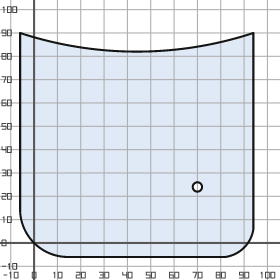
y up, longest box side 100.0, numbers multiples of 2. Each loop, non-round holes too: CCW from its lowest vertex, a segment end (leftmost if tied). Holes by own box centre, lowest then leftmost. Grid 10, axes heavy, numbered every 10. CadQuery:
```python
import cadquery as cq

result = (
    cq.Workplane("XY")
    .moveTo(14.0, -6.0)
    .lineTo(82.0, -6.0)
    .threePointArc((90.0, -2.0), (94.0, 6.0))
    .lineTo(94.0, 90.0)
    .threePointArc((44.0, 82.0), (-6.0, 90.0))
    .lineTo(-6.0, 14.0)
    .threePointArc((0.0, 0.0), (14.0, -6.0))
    .close()
    .moveTo(70.0, 24.0)
    .circle(2.0)
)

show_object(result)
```